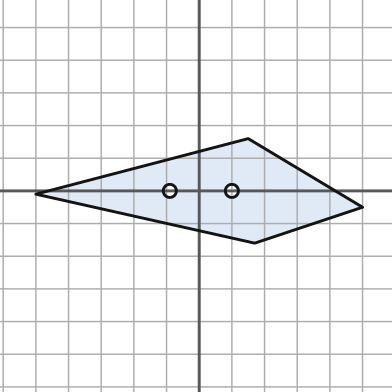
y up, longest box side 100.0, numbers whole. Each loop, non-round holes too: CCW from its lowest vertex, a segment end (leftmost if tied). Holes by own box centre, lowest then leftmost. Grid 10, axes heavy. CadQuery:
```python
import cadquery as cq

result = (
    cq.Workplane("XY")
    .moveTo(17.0, -16.0)
    .lineTo(50.0, -5.0)
    .lineTo(15.0, 16.0)
    .lineTo(-50.0, -1.0)
    .close()
    .moveTo(-9.0, 0.0)
    .circle(2.0)
    .moveTo(10.0, 0.0)
    .circle(2.0)
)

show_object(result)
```